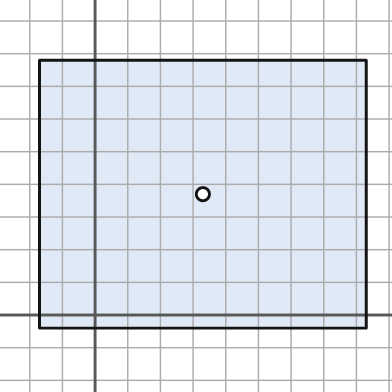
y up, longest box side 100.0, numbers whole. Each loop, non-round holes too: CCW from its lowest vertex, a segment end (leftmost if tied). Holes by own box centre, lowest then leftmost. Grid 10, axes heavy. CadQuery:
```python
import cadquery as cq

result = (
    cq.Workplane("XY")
    .moveTo(-17.0, -4.0)
    .lineTo(83.0, -4.0)
    .lineTo(83.0, 78.0)
    .lineTo(-17.0, 78.0)
    .close()
    .moveTo(33.0, 37.0)
    .circle(2.0)
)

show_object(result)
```